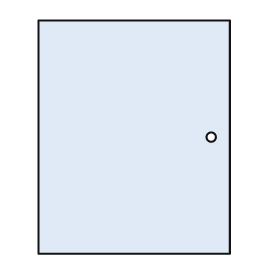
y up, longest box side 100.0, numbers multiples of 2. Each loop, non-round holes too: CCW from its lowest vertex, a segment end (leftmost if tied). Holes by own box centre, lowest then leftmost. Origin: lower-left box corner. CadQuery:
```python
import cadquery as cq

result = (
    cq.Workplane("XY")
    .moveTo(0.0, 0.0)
    .lineTo(82.0, 0.0)
    .lineTo(82.0, 100.0)
    .lineTo(0.0, 100.0)
    .close()
    .moveTo(74.0, 50.0)
    .circle(2.0)
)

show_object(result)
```